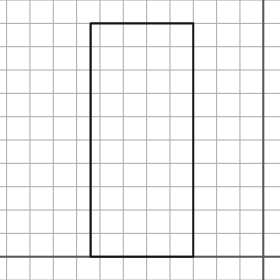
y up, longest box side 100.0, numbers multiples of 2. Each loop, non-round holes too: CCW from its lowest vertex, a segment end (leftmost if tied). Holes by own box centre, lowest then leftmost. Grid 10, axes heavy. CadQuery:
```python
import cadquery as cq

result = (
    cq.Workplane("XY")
    .moveTo(-74.0, 0.0)
    .lineTo(-30.0, 0.0)
    .lineTo(-30.0, 100.0)
    .lineTo(-74.0, 100.0)
    .close()
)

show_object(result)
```